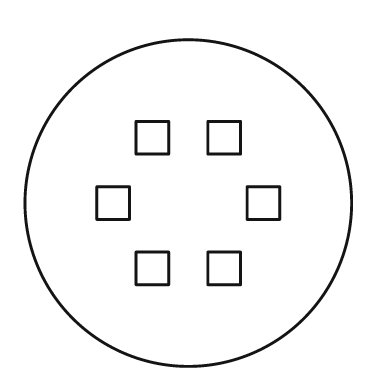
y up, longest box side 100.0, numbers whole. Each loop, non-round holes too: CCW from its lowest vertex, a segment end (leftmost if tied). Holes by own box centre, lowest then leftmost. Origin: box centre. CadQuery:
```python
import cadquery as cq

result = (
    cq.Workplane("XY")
    .moveTo(0.0, 0.0)
    .circle(50.0)
    .moveTo(-16.0, -25.0)
    .lineTo(-6.0, -25.0)
    .lineTo(-6.0, -15.0)
    .lineTo(-16.0, -15.0)
    .close()
    .moveTo(6.0, -25.0)
    .lineTo(16.0, -25.0)
    .lineTo(16.0, -15.0)
    .lineTo(6.0, -15.0)
    .close()
    .moveTo(-28.0, -5.0)
    .lineTo(-18.0, -5.0)
    .lineTo(-18.0, 5.0)
    .lineTo(-28.0, 5.0)
    .close()
    .moveTo(18.0, -5.0)
    .lineTo(28.0, -5.0)
    .lineTo(28.0, 5.0)
    .lineTo(18.0, 5.0)
    .close()
    .moveTo(-16.0, 15.0)
    .lineTo(-6.0, 15.0)
    .lineTo(-6.0, 25.0)
    .lineTo(-16.0, 25.0)
    .close()
    .moveTo(6.0, 15.0)
    .lineTo(16.0, 15.0)
    .lineTo(16.0, 25.0)
    .lineTo(6.0, 25.0)
    .close()
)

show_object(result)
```